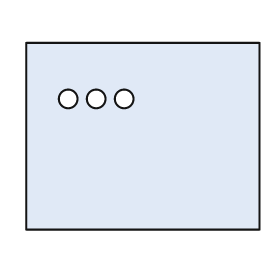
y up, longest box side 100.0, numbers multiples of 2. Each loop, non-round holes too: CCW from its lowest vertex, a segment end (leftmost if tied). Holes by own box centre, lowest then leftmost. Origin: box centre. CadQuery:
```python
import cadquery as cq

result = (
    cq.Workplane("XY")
    .moveTo(-50.0, -40.0)
    .lineTo(50.0, -40.0)
    .lineTo(50.0, 40.0)
    .lineTo(-50.0, 40.0)
    .close()
    .moveTo(-32.0, 16.0)
    .circle(4.0)
    .moveTo(-20.0, 16.0)
    .circle(4.0)
    .moveTo(-8.0, 16.0)
    .circle(4.0)
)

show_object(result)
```